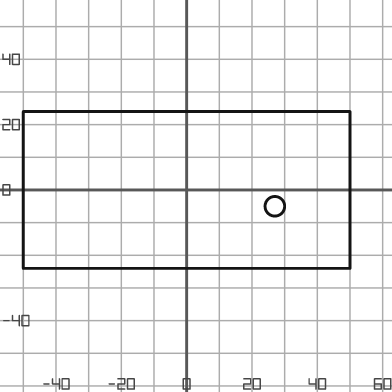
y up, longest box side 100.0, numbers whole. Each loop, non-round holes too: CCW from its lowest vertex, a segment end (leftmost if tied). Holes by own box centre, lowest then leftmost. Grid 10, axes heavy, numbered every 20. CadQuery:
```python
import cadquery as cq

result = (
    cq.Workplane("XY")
    .moveTo(-50.0, -24.0)
    .lineTo(50.0, -24.0)
    .lineTo(50.0, 24.0)
    .lineTo(-50.0, 24.0)
    .close()
    .moveTo(27.0, -5.0)
    .circle(3.0)
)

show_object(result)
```